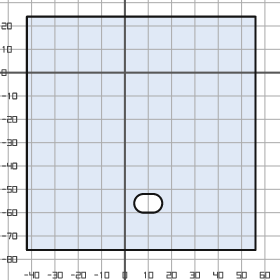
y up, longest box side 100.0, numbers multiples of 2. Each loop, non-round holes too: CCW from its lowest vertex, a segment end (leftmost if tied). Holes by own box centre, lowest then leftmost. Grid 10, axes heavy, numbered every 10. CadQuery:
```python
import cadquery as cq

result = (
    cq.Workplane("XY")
    .moveTo(-42.0, -76.0)
    .lineTo(56.0, -76.0)
    .lineTo(56.0, 24.0)
    .lineTo(-42.0, 24.0)
    .close()
    .moveTo(8.0, -60.0)
    .lineTo(12.0, -60.0)
    .threePointArc((16.0, -56.0), (12.0, -52.0))
    .lineTo(8.0, -52.0)
    .threePointArc((4.0, -56.0), (8.0, -60.0))
    .close()
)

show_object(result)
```